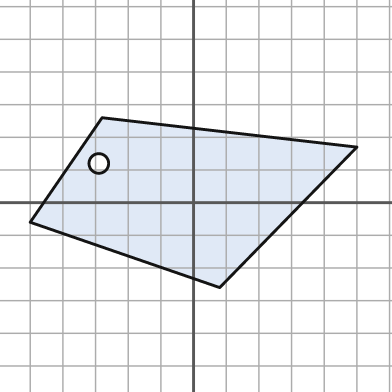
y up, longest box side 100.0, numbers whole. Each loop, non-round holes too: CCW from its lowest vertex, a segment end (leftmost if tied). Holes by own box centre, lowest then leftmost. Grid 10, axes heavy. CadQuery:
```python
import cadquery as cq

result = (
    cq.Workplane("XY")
    .moveTo(8.0, -26.0)
    .lineTo(50.0, 17.0)
    .lineTo(-28.0, 26.0)
    .lineTo(-50.0, -6.0)
    .close()
    .moveTo(-29.0, 12.0)
    .circle(3.0)
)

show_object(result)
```